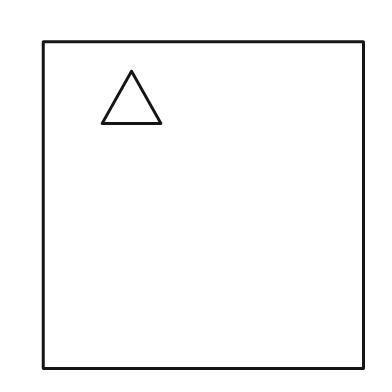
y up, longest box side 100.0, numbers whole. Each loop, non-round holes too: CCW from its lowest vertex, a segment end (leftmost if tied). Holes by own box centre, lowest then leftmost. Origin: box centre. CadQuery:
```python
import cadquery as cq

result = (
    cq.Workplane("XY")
    .moveTo(-49.0, -50.0)
    .lineTo(49.0, -50.0)
    .lineTo(49.0, 50.0)
    .lineTo(-49.0, 50.0)
    .close()
    .moveTo(-31.0, 25.0)
    .lineTo(-13.0, 25.0)
    .lineTo(-22.0, 41.0)
    .close()
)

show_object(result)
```